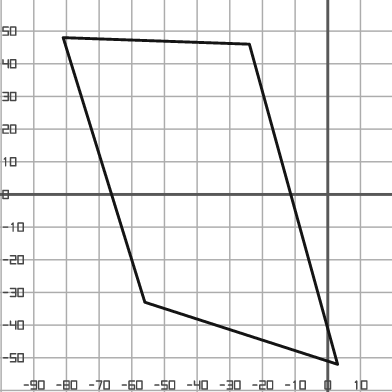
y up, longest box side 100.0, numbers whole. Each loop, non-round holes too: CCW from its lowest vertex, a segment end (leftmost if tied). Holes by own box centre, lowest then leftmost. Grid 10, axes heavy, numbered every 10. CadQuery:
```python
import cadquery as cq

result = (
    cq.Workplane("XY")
    .moveTo(3.0, -52.0)
    .lineTo(-24.0, 46.0)
    .lineTo(-81.0, 48.0)
    .lineTo(-56.0, -33.0)
    .close()
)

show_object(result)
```